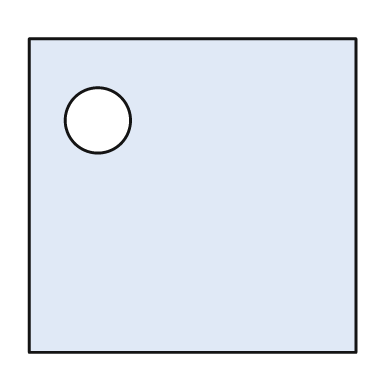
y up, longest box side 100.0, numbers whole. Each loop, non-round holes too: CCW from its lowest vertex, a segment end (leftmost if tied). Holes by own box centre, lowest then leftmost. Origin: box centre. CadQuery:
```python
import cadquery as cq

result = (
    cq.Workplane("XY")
    .moveTo(-50.0, -48.0)
    .lineTo(50.0, -48.0)
    .lineTo(50.0, 48.0)
    .lineTo(-50.0, 48.0)
    .close()
    .moveTo(-29.0, 23.0)
    .circle(10.0)
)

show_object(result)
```